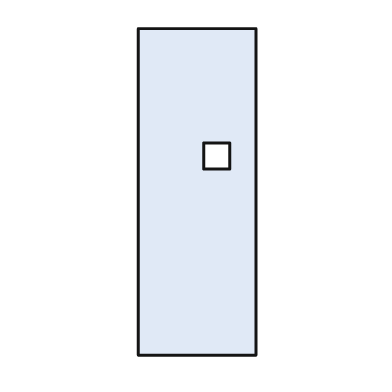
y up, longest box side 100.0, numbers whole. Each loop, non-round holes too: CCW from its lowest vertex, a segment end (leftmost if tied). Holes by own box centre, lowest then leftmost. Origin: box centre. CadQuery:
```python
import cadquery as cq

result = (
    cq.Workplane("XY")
    .moveTo(-18.0, -50.0)
    .lineTo(18.0, -50.0)
    .lineTo(18.0, 50.0)
    .lineTo(-18.0, 50.0)
    .close()
    .moveTo(2.0, 7.0)
    .lineTo(10.0, 7.0)
    .lineTo(10.0, 15.0)
    .lineTo(2.0, 15.0)
    .close()
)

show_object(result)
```